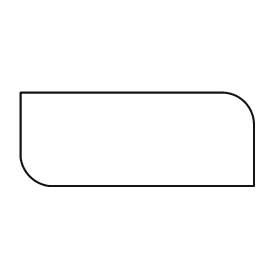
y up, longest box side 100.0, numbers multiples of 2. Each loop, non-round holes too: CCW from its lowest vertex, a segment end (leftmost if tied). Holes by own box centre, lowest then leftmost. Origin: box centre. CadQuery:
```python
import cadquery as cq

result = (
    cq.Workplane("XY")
    .moveTo(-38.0, -20.0)
    .lineTo(50.0, -20.0)
    .lineTo(50.0, 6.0)
    .threePointArc((46.0, 16.0), (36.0, 20.0))
    .lineTo(-50.0, 20.0)
    .lineTo(-50.0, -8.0)
    .threePointArc((-46.0, -16.0), (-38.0, -20.0))
    .close()
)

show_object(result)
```